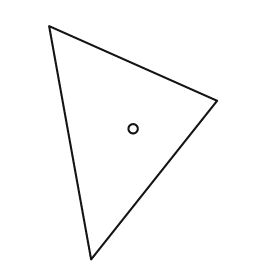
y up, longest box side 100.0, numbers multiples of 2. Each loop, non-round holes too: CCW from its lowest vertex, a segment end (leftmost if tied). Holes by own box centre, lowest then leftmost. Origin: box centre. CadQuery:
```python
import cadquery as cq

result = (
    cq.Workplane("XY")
    .moveTo(-18.0, -50.0)
    .lineTo(36.0, 18.0)
    .lineTo(-36.0, 50.0)
    .close()
    .moveTo(0.0, 6.0)
    .circle(2.0)
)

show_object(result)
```